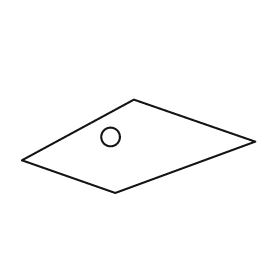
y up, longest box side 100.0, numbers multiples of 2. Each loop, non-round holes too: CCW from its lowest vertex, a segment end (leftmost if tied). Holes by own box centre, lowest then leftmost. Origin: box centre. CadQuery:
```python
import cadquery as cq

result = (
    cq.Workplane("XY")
    .moveTo(-10.0, -20.0)
    .lineTo(50.0, 2.0)
    .lineTo(-2.0, 20.0)
    .lineTo(-50.0, -6.0)
    .close()
    .moveTo(-12.0, 4.0)
    .circle(4.0)
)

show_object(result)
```